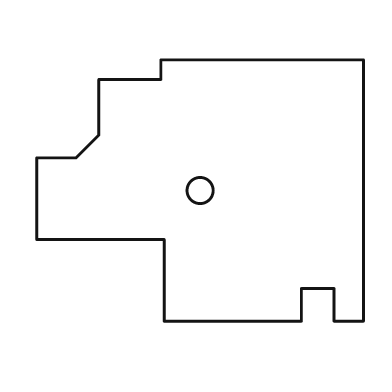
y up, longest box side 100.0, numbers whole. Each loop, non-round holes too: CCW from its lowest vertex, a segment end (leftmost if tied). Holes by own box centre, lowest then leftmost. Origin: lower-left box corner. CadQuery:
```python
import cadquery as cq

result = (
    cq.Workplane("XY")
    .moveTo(39.0, 0.0)
    .lineTo(81.0, 0.0)
    .lineTo(81.0, 10.0)
    .lineTo(91.0, 10.0)
    .lineTo(91.0, 0.0)
    .lineTo(100.0, 0.0)
    .lineTo(100.0, 80.0)
    .lineTo(38.0, 80.0)
    .lineTo(38.0, 74.0)
    .lineTo(19.0, 74.0)
    .lineTo(19.0, 57.0)
    .lineTo(12.0, 50.0)
    .lineTo(0.0, 50.0)
    .lineTo(0.0, 25.0)
    .lineTo(39.0, 25.0)
    .close()
    .moveTo(50.0, 40.0)
    .circle(4.0)
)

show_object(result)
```